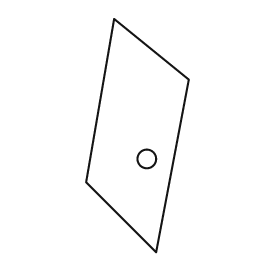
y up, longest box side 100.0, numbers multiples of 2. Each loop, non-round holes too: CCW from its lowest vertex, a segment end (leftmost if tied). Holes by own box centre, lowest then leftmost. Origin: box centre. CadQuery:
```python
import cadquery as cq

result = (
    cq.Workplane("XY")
    .moveTo(8.0, -50.0)
    .lineTo(22.0, 24.0)
    .lineTo(-10.0, 50.0)
    .lineTo(-22.0, -20.0)
    .close()
    .moveTo(4.0, -10.0)
    .circle(4.0)
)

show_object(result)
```